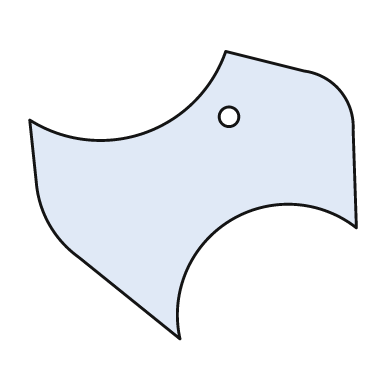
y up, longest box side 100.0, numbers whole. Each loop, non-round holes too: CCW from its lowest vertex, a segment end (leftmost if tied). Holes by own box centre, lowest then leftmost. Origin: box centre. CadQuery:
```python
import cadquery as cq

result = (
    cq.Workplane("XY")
    .moveTo(-4.0, -44.0)
    .threePointArc((11.0, -8.0), (50.0, -10.0))
    .lineTo(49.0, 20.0)
    .threePointArc((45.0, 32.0), (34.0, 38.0))
    .lineTo(10.0, 44.0)
    .threePointArc((-15.0, 19.0), (-50.0, 23.0))
    .lineTo(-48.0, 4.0)
    .threePointArc((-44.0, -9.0), (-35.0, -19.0))
    .close()
    .moveTo(11.0, 24.0)
    .circle(3.0)
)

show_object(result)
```